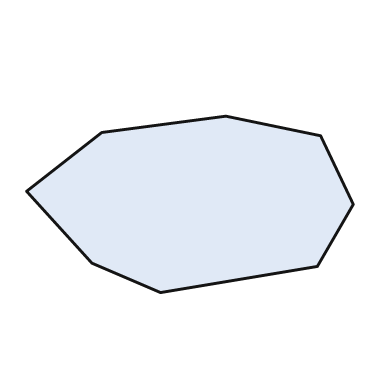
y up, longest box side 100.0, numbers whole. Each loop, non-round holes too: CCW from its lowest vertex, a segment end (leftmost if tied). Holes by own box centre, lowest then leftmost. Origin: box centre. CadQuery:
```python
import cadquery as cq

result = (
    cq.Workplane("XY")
    .moveTo(-9.0, -27.0)
    .lineTo(39.0, -19.0)
    .lineTo(50.0, 0.0)
    .lineTo(40.0, 21.0)
    .lineTo(11.0, 27.0)
    .lineTo(-27.0, 22.0)
    .lineTo(-50.0, 4.0)
    .lineTo(-30.0, -18.0)
    .close()
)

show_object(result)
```